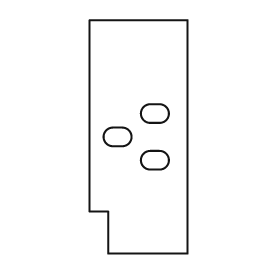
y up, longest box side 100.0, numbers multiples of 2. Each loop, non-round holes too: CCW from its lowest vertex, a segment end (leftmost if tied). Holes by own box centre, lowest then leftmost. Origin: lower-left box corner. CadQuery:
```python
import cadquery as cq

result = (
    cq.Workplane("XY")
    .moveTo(8.0, 0.0)
    .lineTo(42.0, 0.0)
    .lineTo(42.0, 100.0)
    .lineTo(0.0, 100.0)
    .lineTo(0.0, 18.0)
    .lineTo(8.0, 18.0)
    .close()
    .moveTo(26.0, 36.0)
    .lineTo(30.0, 36.0)
    .threePointArc((34.0, 40.0), (30.0, 44.0))
    .lineTo(26.0, 44.0)
    .threePointArc((22.0, 40.0), (26.0, 36.0))
    .close()
    .moveTo(10.0, 46.0)
    .lineTo(14.0, 46.0)
    .threePointArc((18.0, 50.0), (14.0, 54.0))
    .lineTo(10.0, 54.0)
    .threePointArc((6.0, 50.0), (10.0, 46.0))
    .close()
    .moveTo(26.0, 56.0)
    .lineTo(30.0, 56.0)
    .threePointArc((34.0, 60.0), (30.0, 64.0))
    .lineTo(26.0, 64.0)
    .threePointArc((22.0, 60.0), (26.0, 56.0))
    .close()
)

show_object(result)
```